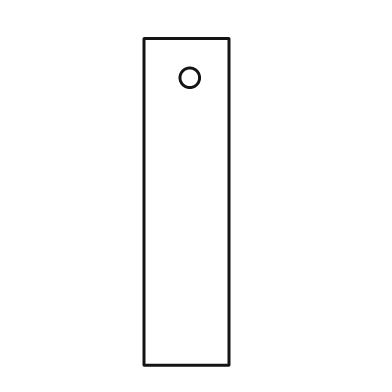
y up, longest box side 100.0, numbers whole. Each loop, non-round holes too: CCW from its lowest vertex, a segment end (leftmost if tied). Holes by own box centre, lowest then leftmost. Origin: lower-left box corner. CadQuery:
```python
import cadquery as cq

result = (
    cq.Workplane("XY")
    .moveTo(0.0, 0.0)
    .lineTo(26.0, 0.0)
    .lineTo(26.0, 100.0)
    .lineTo(0.0, 100.0)
    .close()
    .moveTo(14.0, 88.0)
    .circle(3.0)
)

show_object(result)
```